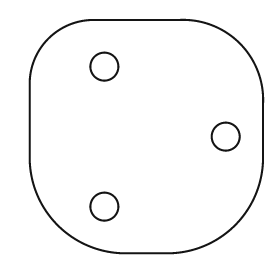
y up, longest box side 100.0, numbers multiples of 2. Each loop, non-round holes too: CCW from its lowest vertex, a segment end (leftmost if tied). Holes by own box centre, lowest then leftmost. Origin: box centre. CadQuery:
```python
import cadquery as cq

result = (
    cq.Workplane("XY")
    .moveTo(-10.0, -50.0)
    .lineTo(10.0, -50.0)
    .threePointArc((38.0, -38.0), (50.0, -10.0))
    .lineTo(50.0, 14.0)
    .threePointArc((40.0, 40.0), (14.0, 50.0))
    .lineTo(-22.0, 50.0)
    .threePointArc((-42.0, 42.0), (-50.0, 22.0))
    .lineTo(-50.0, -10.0)
    .threePointArc((-38.0, -38.0), (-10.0, -50.0))
    .close()
    .moveTo(-18.0, -30.0)
    .circle(6.0)
    .moveTo(34.0, 0.0)
    .circle(6.0)
    .moveTo(-18.0, 30.0)
    .circle(6.0)
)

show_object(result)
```